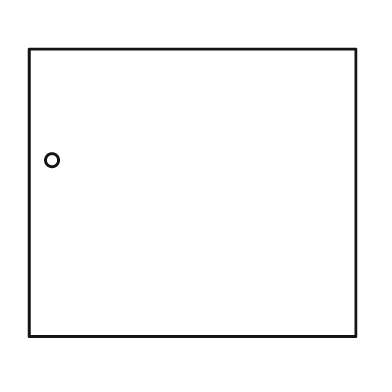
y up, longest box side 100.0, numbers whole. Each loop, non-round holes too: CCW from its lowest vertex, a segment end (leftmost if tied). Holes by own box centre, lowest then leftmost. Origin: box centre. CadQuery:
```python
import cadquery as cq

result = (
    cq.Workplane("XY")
    .moveTo(-50.0, -44.0)
    .lineTo(50.0, -44.0)
    .lineTo(50.0, 44.0)
    .lineTo(-50.0, 44.0)
    .close()
    .moveTo(-43.0, 10.0)
    .circle(2.0)
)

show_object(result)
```